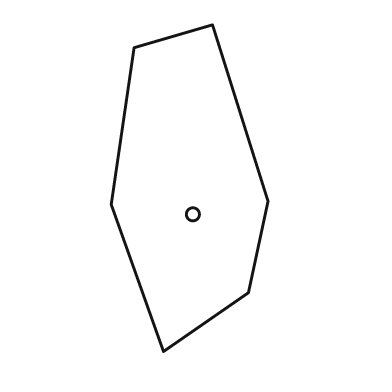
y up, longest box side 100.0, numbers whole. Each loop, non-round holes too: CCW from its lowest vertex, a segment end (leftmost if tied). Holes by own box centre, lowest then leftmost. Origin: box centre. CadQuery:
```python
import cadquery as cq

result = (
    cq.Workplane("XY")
    .moveTo(-8.0, -50.0)
    .lineTo(18.0, -32.0)
    .lineTo(24.0, -4.0)
    .lineTo(7.0, 50.0)
    .lineTo(-17.0, 43.0)
    .lineTo(-24.0, -5.0)
    .close()
    .moveTo(1.0, -8.0)
    .circle(2.0)
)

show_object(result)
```